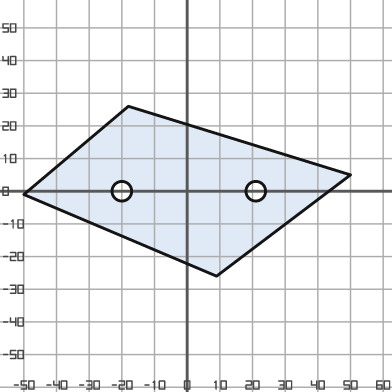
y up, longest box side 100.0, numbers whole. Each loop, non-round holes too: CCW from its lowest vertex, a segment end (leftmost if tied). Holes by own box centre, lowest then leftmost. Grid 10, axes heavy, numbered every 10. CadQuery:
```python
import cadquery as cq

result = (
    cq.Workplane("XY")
    .moveTo(9.0, -26.0)
    .lineTo(50.0, 5.0)
    .lineTo(-18.0, 26.0)
    .lineTo(-50.0, -1.0)
    .close()
    .moveTo(-20.0, 0.0)
    .circle(3.0)
    .moveTo(21.0, 0.0)
    .circle(3.0)
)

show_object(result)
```